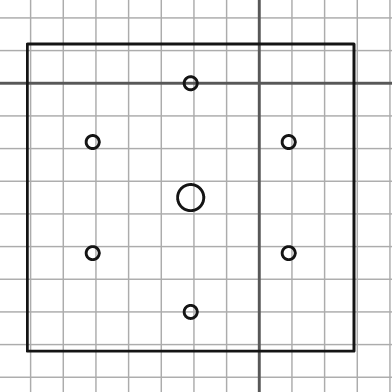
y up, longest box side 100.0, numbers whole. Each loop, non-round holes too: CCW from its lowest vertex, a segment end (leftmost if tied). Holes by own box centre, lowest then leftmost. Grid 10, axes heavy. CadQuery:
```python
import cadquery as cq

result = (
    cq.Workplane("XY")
    .moveTo(-71.0, -82.0)
    .lineTo(29.0, -82.0)
    .lineTo(29.0, 12.0)
    .lineTo(-71.0, 12.0)
    .close()
    .moveTo(-21.0, -70.0)
    .circle(2.0)
    .moveTo(-51.0, -52.0)
    .circle(2.0)
    .moveTo(9.0, -52.0)
    .circle(2.0)
    .moveTo(-21.0, -35.0)
    .circle(4.0)
    .moveTo(-51.0, -18.0)
    .circle(2.0)
    .moveTo(9.0, -18.0)
    .circle(2.0)
    .moveTo(-21.0, 0.0)
    .circle(2.0)
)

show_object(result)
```